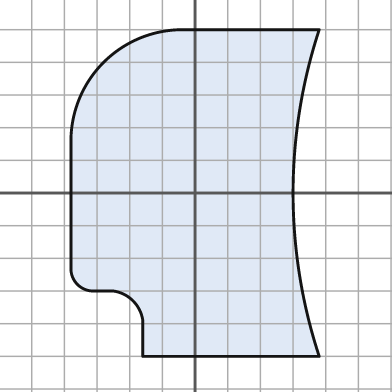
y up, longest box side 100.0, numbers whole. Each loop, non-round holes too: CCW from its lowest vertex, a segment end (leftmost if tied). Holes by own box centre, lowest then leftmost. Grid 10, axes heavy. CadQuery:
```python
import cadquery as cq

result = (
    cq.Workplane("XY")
    .moveTo(-16.0, -50.0)
    .lineTo(38.0, -50.0)
    .threePointArc((30.0, 0.0), (38.0, 50.0))
    .lineTo(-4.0, 50.0)
    .threePointArc((-28.0, 40.0), (-38.0, 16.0))
    .lineTo(-38.0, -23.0)
    .threePointArc((-36.0, -28.0), (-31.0, -30.0))
    .lineTo(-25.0, -30.0)
    .threePointArc((-19.0, -33.0), (-16.0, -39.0))
    .close()
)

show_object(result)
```